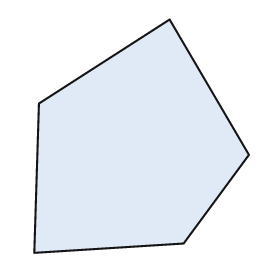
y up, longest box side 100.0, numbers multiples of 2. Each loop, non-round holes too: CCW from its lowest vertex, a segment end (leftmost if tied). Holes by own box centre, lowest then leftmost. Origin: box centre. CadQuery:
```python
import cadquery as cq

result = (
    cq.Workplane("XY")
    .moveTo(-46.0, -50.0)
    .lineTo(18.0, -46.0)
    .lineTo(46.0, -8.0)
    .lineTo(12.0, 50.0)
    .lineTo(-44.0, 14.0)
    .close()
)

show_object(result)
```